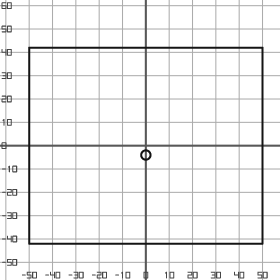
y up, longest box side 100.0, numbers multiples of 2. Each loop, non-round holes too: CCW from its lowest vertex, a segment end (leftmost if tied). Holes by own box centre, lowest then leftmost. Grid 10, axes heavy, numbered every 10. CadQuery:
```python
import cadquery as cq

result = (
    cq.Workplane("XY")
    .moveTo(-50.0, -42.0)
    .lineTo(50.0, -42.0)
    .lineTo(50.0, 42.0)
    .lineTo(-50.0, 42.0)
    .close()
    .moveTo(0.0, -4.0)
    .circle(2.0)
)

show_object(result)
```